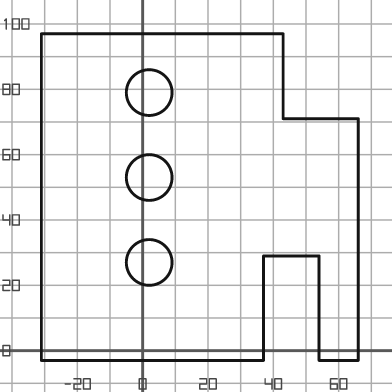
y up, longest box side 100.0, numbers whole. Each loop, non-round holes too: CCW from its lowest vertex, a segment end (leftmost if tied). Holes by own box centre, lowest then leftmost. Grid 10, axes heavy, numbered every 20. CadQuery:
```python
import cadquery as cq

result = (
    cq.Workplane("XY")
    .moveTo(-31.0, -3.0)
    .lineTo(37.0, -3.0)
    .lineTo(37.0, 29.0)
    .lineTo(54.0, 29.0)
    .lineTo(54.0, -3.0)
    .lineTo(66.0, -3.0)
    .lineTo(66.0, 71.0)
    .lineTo(43.0, 71.0)
    .lineTo(43.0, 97.0)
    .lineTo(-31.0, 97.0)
    .close()
    .moveTo(2.0, 27.0)
    .circle(7.0)
    .moveTo(2.0, 53.0)
    .circle(7.0)
    .moveTo(2.0, 79.0)
    .circle(7.0)
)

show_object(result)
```